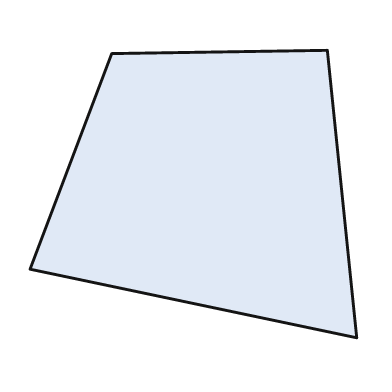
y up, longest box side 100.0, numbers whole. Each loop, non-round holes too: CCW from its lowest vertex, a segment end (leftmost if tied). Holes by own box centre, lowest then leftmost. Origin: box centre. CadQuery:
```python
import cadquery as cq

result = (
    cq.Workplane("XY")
    .moveTo(50.0, -44.0)
    .lineTo(41.0, 44.0)
    .lineTo(-25.0, 43.0)
    .lineTo(-50.0, -23.0)
    .close()
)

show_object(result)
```